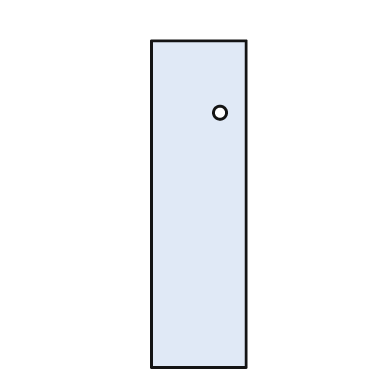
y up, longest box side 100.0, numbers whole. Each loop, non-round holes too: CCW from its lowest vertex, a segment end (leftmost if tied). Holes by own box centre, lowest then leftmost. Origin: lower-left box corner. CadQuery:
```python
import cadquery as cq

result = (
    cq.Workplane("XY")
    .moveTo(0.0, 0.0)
    .lineTo(29.0, 0.0)
    .lineTo(29.0, 100.0)
    .lineTo(0.0, 100.0)
    .close()
    .moveTo(21.0, 78.0)
    .circle(2.0)
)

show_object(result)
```